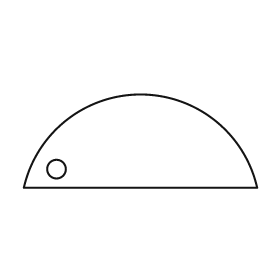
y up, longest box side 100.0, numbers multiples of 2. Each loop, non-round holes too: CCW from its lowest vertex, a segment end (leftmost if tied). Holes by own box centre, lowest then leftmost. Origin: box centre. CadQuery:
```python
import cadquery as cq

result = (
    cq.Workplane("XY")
    .moveTo(-50.0, -20.0)
    .lineTo(50.0, -20.0)
    .threePointArc((0.0, 20.0), (-50.0, -20.0))
    .close()
    .moveTo(-36.0, -12.0)
    .circle(4.0)
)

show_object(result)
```